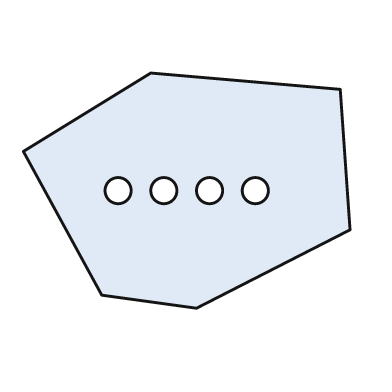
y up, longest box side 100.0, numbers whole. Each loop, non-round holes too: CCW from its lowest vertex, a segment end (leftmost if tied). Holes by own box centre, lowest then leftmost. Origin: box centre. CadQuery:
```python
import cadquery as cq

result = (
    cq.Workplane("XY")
    .moveTo(3.0, -36.0)
    .lineTo(50.0, -12.0)
    .lineTo(47.0, 31.0)
    .lineTo(-11.0, 36.0)
    .lineTo(-50.0, 12.0)
    .lineTo(-26.0, -32.0)
    .close()
    .moveTo(-21.0, 0.0)
    .circle(4.0)
    .moveTo(-7.0, 0.0)
    .circle(4.0)
    .moveTo(7.0, 0.0)
    .circle(4.0)
    .moveTo(21.0, 0.0)
    .circle(4.0)
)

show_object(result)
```